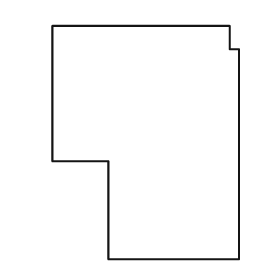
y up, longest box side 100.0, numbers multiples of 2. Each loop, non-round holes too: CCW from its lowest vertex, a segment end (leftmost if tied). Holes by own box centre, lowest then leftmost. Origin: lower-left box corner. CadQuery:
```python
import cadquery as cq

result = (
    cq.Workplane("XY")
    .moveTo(24.0, 0.0)
    .lineTo(80.0, 0.0)
    .lineTo(80.0, 90.0)
    .lineTo(76.0, 90.0)
    .lineTo(76.0, 100.0)
    .lineTo(0.0, 100.0)
    .lineTo(0.0, 42.0)
    .lineTo(24.0, 42.0)
    .close()
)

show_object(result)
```